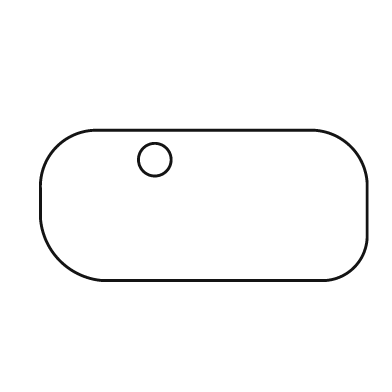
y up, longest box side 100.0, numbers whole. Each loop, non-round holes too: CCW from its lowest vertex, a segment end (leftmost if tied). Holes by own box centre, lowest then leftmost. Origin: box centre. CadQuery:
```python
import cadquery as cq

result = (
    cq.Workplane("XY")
    .moveTo(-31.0, -23.0)
    .lineTo(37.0, -23.0)
    .threePointArc((46.0, -19.0), (50.0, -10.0))
    .lineTo(50.0, 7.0)
    .threePointArc((45.0, 18.0), (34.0, 23.0))
    .lineTo(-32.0, 23.0)
    .threePointArc((-45.0, 18.0), (-50.0, 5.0))
    .lineTo(-50.0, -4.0)
    .threePointArc((-44.0, -17.0), (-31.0, -23.0))
    .close()
    .moveTo(-15.0, 14.0)
    .circle(5.0)
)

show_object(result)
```